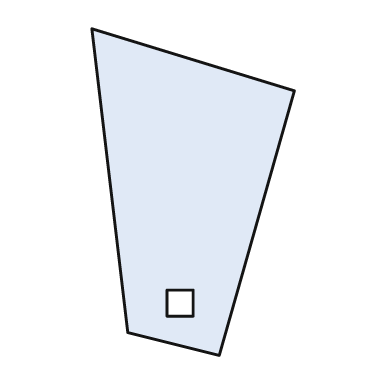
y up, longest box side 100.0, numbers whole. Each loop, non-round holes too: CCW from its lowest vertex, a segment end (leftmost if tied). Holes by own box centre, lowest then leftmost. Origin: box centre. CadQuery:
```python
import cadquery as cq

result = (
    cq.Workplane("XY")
    .moveTo(8.0, -50.0)
    .lineTo(31.0, 31.0)
    .lineTo(-31.0, 50.0)
    .lineTo(-20.0, -43.0)
    .close()
    .moveTo(-8.0, -38.0)
    .lineTo(0.0, -38.0)
    .lineTo(0.0, -30.0)
    .lineTo(-8.0, -30.0)
    .close()
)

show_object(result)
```